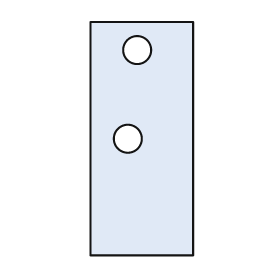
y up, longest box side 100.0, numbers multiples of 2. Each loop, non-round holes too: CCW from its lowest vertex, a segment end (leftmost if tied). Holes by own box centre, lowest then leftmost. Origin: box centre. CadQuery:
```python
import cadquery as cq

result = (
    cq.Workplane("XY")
    .moveTo(-22.0, -50.0)
    .lineTo(22.0, -50.0)
    .lineTo(22.0, 50.0)
    .lineTo(-22.0, 50.0)
    .close()
    .moveTo(-6.0, 0.0)
    .circle(6.0)
    .moveTo(-2.0, 38.0)
    .circle(6.0)
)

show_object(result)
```